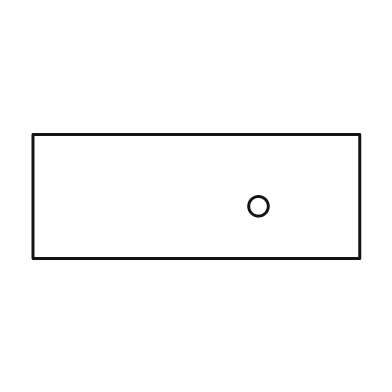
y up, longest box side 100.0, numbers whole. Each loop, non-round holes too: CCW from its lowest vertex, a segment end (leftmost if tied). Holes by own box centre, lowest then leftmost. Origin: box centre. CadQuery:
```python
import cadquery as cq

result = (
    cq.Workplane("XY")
    .moveTo(-50.0, -19.0)
    .lineTo(50.0, -19.0)
    .lineTo(50.0, 19.0)
    .lineTo(-50.0, 19.0)
    .close()
    .moveTo(19.0, -3.0)
    .circle(3.0)
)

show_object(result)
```